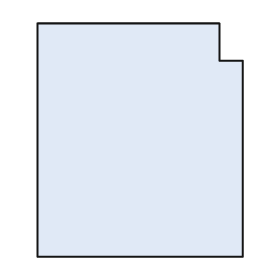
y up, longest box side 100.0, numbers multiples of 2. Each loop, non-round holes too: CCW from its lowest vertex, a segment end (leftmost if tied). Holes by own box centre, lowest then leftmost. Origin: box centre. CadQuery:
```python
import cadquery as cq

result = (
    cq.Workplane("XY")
    .moveTo(-44.0, -50.0)
    .lineTo(44.0, -50.0)
    .lineTo(44.0, 34.0)
    .lineTo(34.0, 34.0)
    .lineTo(34.0, 50.0)
    .lineTo(-44.0, 50.0)
    .close()
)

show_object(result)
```